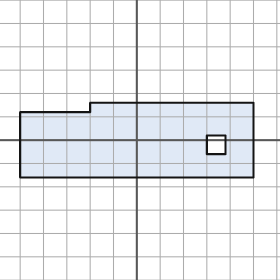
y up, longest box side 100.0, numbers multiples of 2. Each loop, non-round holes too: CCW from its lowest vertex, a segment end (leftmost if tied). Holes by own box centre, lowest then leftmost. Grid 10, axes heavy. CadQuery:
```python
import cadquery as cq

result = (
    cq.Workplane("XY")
    .moveTo(-50.0, -16.0)
    .lineTo(50.0, -16.0)
    .lineTo(50.0, 16.0)
    .lineTo(-20.0, 16.0)
    .lineTo(-20.0, 12.0)
    .lineTo(-50.0, 12.0)
    .close()
    .moveTo(30.0, -6.0)
    .lineTo(38.0, -6.0)
    .lineTo(38.0, 2.0)
    .lineTo(30.0, 2.0)
    .close()
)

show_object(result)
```